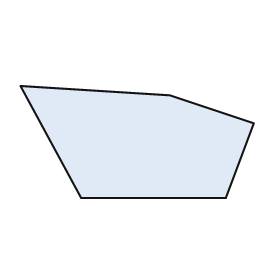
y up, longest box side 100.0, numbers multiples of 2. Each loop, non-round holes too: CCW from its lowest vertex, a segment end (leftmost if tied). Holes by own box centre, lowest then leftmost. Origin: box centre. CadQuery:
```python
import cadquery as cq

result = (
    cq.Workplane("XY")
    .moveTo(-24.0, -24.0)
    .lineTo(38.0, -24.0)
    .lineTo(50.0, 8.0)
    .lineTo(14.0, 20.0)
    .lineTo(-50.0, 24.0)
    .close()
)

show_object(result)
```